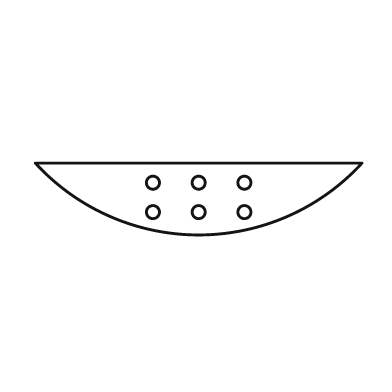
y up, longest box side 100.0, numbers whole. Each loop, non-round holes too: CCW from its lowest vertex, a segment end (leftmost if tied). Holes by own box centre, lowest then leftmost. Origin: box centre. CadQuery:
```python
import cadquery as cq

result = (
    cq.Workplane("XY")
    .moveTo(-50.0, 11.0)
    .threePointArc((0.0, -11.0), (50.0, 11.0))
    .close()
    .moveTo(-14.0, -4.0)
    .circle(2.0)
    .moveTo(0.0, -4.0)
    .circle(2.0)
    .moveTo(14.0, -4.0)
    .circle(2.0)
    .moveTo(-14.0, 5.0)
    .circle(2.0)
    .moveTo(0.0, 5.0)
    .circle(2.0)
    .moveTo(14.0, 5.0)
    .circle(2.0)
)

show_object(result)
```